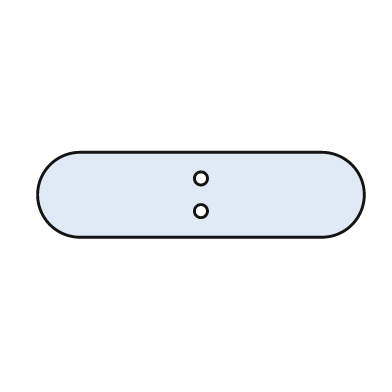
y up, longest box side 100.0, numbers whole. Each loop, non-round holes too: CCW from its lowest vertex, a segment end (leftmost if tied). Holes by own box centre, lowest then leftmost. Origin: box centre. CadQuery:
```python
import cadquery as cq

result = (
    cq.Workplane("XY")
    .moveTo(-37.0, -13.0)
    .lineTo(37.0, -13.0)
    .threePointArc((50.0, 0.0), (37.0, 13.0))
    .lineTo(-37.0, 13.0)
    .threePointArc((-50.0, 0.0), (-37.0, -13.0))
    .close()
    .moveTo(0.0, -5.0)
    .circle(2.0)
    .moveTo(0.0, 5.0)
    .circle(2.0)
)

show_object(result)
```